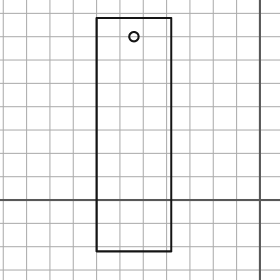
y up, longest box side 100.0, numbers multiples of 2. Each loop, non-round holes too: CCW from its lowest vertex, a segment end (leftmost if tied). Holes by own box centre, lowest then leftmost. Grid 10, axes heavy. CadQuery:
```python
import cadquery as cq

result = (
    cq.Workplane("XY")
    .moveTo(-70.0, -22.0)
    .lineTo(-38.0, -22.0)
    .lineTo(-38.0, 78.0)
    .lineTo(-70.0, 78.0)
    .close()
    .moveTo(-54.0, 70.0)
    .circle(2.0)
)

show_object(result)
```